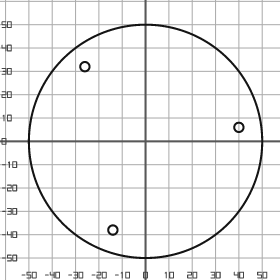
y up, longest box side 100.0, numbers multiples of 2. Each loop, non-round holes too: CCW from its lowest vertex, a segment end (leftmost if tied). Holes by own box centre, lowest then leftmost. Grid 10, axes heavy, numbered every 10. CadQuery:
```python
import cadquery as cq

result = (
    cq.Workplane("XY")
    .moveTo(0.0, 0.0)
    .circle(50.0)
    .moveTo(-14.0, -38.0)
    .circle(2.0)
    .moveTo(40.0, 6.0)
    .circle(2.0)
    .moveTo(-26.0, 32.0)
    .circle(2.0)
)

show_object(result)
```